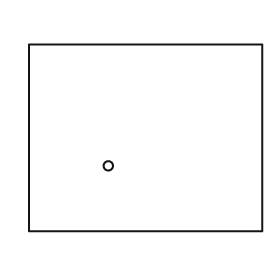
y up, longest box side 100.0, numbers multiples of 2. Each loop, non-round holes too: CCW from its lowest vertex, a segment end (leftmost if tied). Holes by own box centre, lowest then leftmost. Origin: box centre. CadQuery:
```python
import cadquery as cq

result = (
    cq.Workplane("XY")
    .moveTo(-50.0, -40.0)
    .lineTo(50.0, -40.0)
    .lineTo(50.0, 40.0)
    .lineTo(-50.0, 40.0)
    .close()
    .moveTo(-16.0, -12.0)
    .circle(2.0)
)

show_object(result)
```